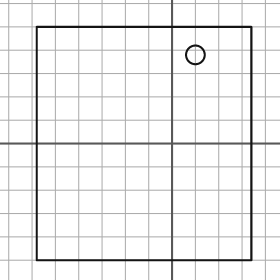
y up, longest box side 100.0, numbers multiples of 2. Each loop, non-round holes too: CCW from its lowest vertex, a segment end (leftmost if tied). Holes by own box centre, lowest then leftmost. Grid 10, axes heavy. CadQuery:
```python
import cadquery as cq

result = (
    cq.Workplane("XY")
    .moveTo(-58.0, -50.0)
    .lineTo(34.0, -50.0)
    .lineTo(34.0, 50.0)
    .lineTo(-58.0, 50.0)
    .close()
    .moveTo(10.0, 38.0)
    .circle(4.0)
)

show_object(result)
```